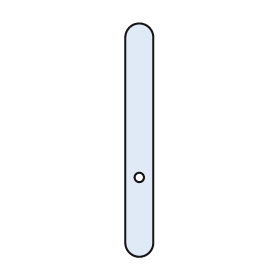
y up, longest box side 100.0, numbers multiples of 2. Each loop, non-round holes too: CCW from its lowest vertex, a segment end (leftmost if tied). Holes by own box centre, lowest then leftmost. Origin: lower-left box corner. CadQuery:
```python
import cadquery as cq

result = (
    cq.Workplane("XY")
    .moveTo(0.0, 6.0)
    .threePointArc((6.0, 0.0), (12.0, 6.0))
    .lineTo(12.0, 94.0)
    .threePointArc((6.0, 100.0), (0.0, 94.0))
    .close()
    .moveTo(6.0, 34.0)
    .circle(2.0)
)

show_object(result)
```